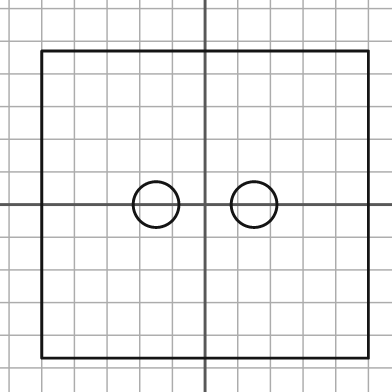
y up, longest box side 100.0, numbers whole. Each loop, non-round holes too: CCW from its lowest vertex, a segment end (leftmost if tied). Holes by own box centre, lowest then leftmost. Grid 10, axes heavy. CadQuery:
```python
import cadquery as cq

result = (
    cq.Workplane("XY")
    .moveTo(-50.0, -47.0)
    .lineTo(50.0, -47.0)
    .lineTo(50.0, 47.0)
    .lineTo(-50.0, 47.0)
    .close()
    .moveTo(-15.0, 0.0)
    .circle(7.0)
    .moveTo(15.0, 0.0)
    .circle(7.0)
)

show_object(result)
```